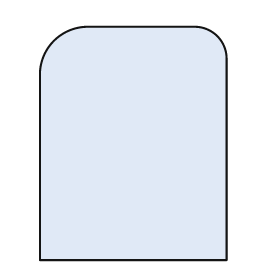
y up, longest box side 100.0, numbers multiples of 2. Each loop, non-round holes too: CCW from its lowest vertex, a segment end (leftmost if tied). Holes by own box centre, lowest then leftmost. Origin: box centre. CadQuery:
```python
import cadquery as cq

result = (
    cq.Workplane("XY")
    .moveTo(-40.0, -50.0)
    .lineTo(40.0, -50.0)
    .lineTo(40.0, 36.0)
    .threePointArc((36.0, 46.0), (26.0, 50.0))
    .lineTo(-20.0, 50.0)
    .threePointArc((-34.0, 44.0), (-40.0, 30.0))
    .close()
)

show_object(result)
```